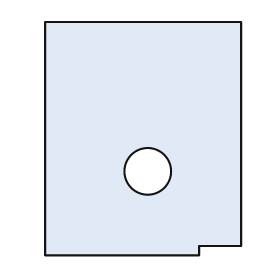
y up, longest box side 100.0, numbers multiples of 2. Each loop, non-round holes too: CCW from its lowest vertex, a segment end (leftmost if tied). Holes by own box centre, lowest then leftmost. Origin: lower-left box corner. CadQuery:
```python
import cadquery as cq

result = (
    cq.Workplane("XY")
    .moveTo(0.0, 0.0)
    .lineTo(66.0, 0.0)
    .lineTo(66.0, 4.0)
    .lineTo(84.0, 4.0)
    .lineTo(84.0, 100.0)
    .lineTo(0.0, 100.0)
    .close()
    .moveTo(44.0, 36.0)
    .circle(10.0)
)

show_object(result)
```